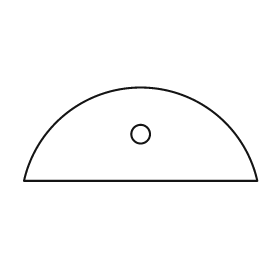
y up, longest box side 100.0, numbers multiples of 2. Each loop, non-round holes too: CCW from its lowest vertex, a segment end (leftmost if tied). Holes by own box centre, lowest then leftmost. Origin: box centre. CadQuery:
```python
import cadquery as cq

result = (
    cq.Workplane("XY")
    .moveTo(-50.0, -20.0)
    .lineTo(50.0, -20.0)
    .threePointArc((0.0, 20.0), (-50.0, -20.0))
    .close()
    .moveTo(0.0, 0.0)
    .circle(4.0)
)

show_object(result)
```